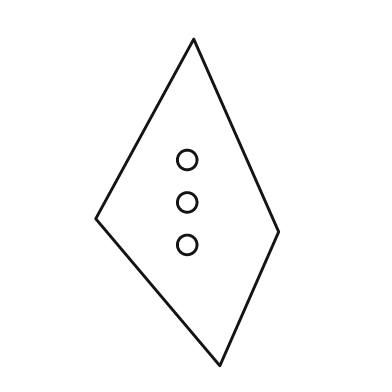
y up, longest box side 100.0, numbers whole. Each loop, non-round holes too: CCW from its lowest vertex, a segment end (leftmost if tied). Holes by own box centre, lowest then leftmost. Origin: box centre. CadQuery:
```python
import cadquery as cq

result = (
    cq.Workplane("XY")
    .moveTo(10.0, -50.0)
    .lineTo(28.0, -9.0)
    .lineTo(2.0, 50.0)
    .lineTo(-28.0, -5.0)
    .close()
    .moveTo(0.0, -13.0)
    .circle(3.0)
    .moveTo(0.0, 0.0)
    .circle(3.0)
    .moveTo(0.0, 13.0)
    .circle(3.0)
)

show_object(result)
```